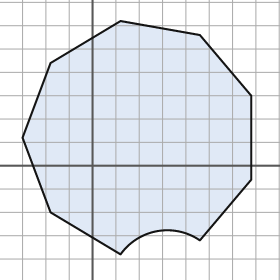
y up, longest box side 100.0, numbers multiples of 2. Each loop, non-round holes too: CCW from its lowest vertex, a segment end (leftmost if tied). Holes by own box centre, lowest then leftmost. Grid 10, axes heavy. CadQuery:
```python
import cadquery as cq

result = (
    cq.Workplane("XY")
    .moveTo(12.0, -38.0)
    .threePointArc((28.0, -28.0), (46.0, -32.0))
    .lineTo(68.0, -6.0)
    .lineTo(68.0, 30.0)
    .lineTo(46.0, 56.0)
    .lineTo(12.0, 62.0)
    .lineTo(-18.0, 44.0)
    .lineTo(-30.0, 12.0)
    .lineTo(-18.0, -20.0)
    .close()
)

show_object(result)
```